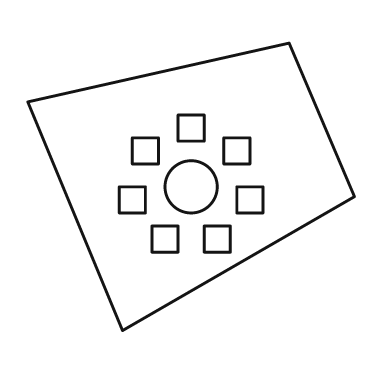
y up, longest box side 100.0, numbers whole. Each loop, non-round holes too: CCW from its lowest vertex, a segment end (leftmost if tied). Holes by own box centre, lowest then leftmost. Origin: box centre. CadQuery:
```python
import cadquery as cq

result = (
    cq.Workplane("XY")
    .moveTo(-21.0, -44.0)
    .lineTo(50.0, -3.0)
    .lineTo(30.0, 44.0)
    .lineTo(-50.0, 26.0)
    .close()
    .moveTo(-12.0, -20.0)
    .lineTo(-4.0, -20.0)
    .lineTo(-4.0, -12.0)
    .lineTo(-12.0, -12.0)
    .close()
    .moveTo(4.0, -20.0)
    .lineTo(12.0, -20.0)
    .lineTo(12.0, -12.0)
    .lineTo(4.0, -12.0)
    .close()
    .moveTo(-22.0, -8.0)
    .lineTo(-14.0, -8.0)
    .lineTo(-14.0, 0.0)
    .lineTo(-22.0, 0.0)
    .close()
    .moveTo(14.0, -8.0)
    .lineTo(22.0, -8.0)
    .lineTo(22.0, 0.0)
    .lineTo(14.0, 0.0)
    .close()
    .moveTo(0.0, 0.0)
    .circle(8.0)
    .moveTo(-18.0, 7.0)
    .lineTo(-10.0, 7.0)
    .lineTo(-10.0, 15.0)
    .lineTo(-18.0, 15.0)
    .close()
    .moveTo(10.0, 7.0)
    .lineTo(18.0, 7.0)
    .lineTo(18.0, 15.0)
    .lineTo(10.0, 15.0)
    .close()
    .moveTo(-4.0, 14.0)
    .lineTo(4.0, 14.0)
    .lineTo(4.0, 22.0)
    .lineTo(-4.0, 22.0)
    .close()
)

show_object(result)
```